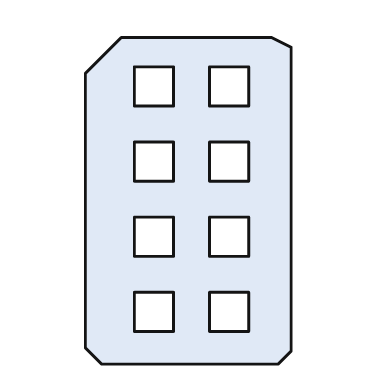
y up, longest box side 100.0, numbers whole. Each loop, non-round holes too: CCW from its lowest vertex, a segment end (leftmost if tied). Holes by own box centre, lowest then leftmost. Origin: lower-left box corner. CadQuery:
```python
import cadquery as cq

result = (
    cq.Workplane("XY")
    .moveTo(5.0, 0.0)
    .lineTo(59.0, 0.0)
    .lineTo(63.0, 4.0)
    .lineTo(63.0, 97.0)
    .lineTo(57.0, 100.0)
    .lineTo(11.0, 100.0)
    .lineTo(0.0, 89.0)
    .lineTo(0.0, 5.0)
    .close()
    .moveTo(15.0, 10.0)
    .lineTo(27.0, 10.0)
    .lineTo(27.0, 22.0)
    .lineTo(15.0, 22.0)
    .close()
    .moveTo(38.0, 10.0)
    .lineTo(50.0, 10.0)
    .lineTo(50.0, 22.0)
    .lineTo(38.0, 22.0)
    .close()
    .moveTo(15.0, 33.0)
    .lineTo(27.0, 33.0)
    .lineTo(27.0, 45.0)
    .lineTo(15.0, 45.0)
    .close()
    .moveTo(38.0, 33.0)
    .lineTo(50.0, 33.0)
    .lineTo(50.0, 45.0)
    .lineTo(38.0, 45.0)
    .close()
    .moveTo(15.0, 56.0)
    .lineTo(27.0, 56.0)
    .lineTo(27.0, 68.0)
    .lineTo(15.0, 68.0)
    .close()
    .moveTo(38.0, 56.0)
    .lineTo(50.0, 56.0)
    .lineTo(50.0, 68.0)
    .lineTo(38.0, 68.0)
    .close()
    .moveTo(15.0, 79.0)
    .lineTo(27.0, 79.0)
    .lineTo(27.0, 91.0)
    .lineTo(15.0, 91.0)
    .close()
    .moveTo(38.0, 79.0)
    .lineTo(50.0, 79.0)
    .lineTo(50.0, 91.0)
    .lineTo(38.0, 91.0)
    .close()
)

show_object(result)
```